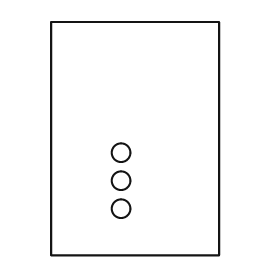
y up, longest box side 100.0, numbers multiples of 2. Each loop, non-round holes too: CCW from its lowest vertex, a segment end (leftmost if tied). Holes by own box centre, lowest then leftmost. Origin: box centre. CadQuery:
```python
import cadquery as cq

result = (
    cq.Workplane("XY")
    .moveTo(-36.0, -50.0)
    .lineTo(36.0, -50.0)
    .lineTo(36.0, 50.0)
    .lineTo(-36.0, 50.0)
    .close()
    .moveTo(-6.0, -30.0)
    .circle(4.0)
    .moveTo(-6.0, -18.0)
    .circle(4.0)
    .moveTo(-6.0, -6.0)
    .circle(4.0)
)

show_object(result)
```